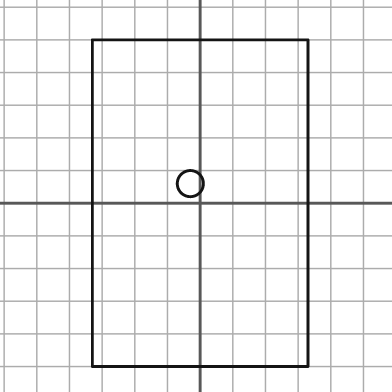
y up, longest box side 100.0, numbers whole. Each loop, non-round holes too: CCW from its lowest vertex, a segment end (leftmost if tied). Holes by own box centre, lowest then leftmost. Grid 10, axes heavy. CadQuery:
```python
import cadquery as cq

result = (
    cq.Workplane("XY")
    .moveTo(-33.0, -50.0)
    .lineTo(33.0, -50.0)
    .lineTo(33.0, 50.0)
    .lineTo(-33.0, 50.0)
    .close()
    .moveTo(-3.0, 6.0)
    .circle(4.0)
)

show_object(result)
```